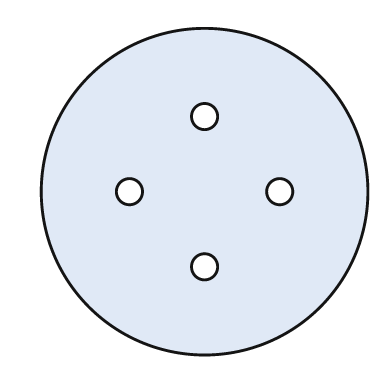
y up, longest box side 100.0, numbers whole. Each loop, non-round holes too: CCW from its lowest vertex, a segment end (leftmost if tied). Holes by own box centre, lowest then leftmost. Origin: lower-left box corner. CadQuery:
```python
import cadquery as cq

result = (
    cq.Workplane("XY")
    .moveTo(50.0, 50.0)
    .circle(50.0)
    .moveTo(50.0, 27.0)
    .circle(4.0)
    .moveTo(27.0, 50.0)
    .circle(4.0)
    .moveTo(73.0, 50.0)
    .circle(4.0)
    .moveTo(50.0, 73.0)
    .circle(4.0)
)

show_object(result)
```